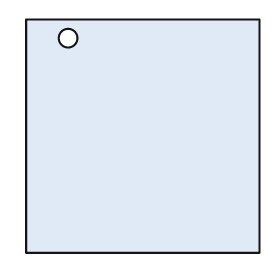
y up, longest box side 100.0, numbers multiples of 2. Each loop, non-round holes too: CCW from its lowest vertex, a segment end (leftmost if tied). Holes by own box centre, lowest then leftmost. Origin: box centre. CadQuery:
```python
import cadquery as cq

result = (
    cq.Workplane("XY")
    .moveTo(-50.0, -50.0)
    .lineTo(50.0, -50.0)
    .lineTo(50.0, 50.0)
    .lineTo(-50.0, 50.0)
    .close()
    .moveTo(-32.0, 42.0)
    .circle(4.0)
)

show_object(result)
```